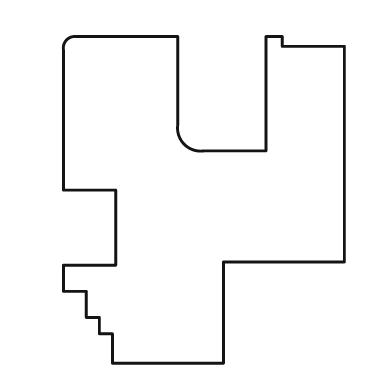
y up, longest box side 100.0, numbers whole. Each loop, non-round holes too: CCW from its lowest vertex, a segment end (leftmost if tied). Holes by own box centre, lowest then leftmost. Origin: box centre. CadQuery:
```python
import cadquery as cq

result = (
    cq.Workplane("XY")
    .moveTo(-28.0, -50.0)
    .lineTo(6.0, -50.0)
    .lineTo(6.0, -19.0)
    .lineTo(43.0, -19.0)
    .lineTo(43.0, 47.0)
    .lineTo(24.0, 47.0)
    .lineTo(24.0, 50.0)
    .lineTo(19.0, 50.0)
    .lineTo(19.0, 15.0)
    .lineTo(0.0, 15.0)
    .threePointArc((-6.0, 17.0), (-8.0, 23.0))
    .lineTo(-8.0, 50.0)
    .lineTo(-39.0, 50.0)
    .threePointArc((-42.0, 49.0), (-43.0, 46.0))
    .lineTo(-43.0, 3.0)
    .lineTo(-27.0, 3.0)
    .lineTo(-27.0, -20.0)
    .lineTo(-43.0, -20.0)
    .lineTo(-43.0, -28.0)
    .lineTo(-36.0, -28.0)
    .lineTo(-36.0, -36.0)
    .lineTo(-32.0, -36.0)
    .lineTo(-32.0, -41.0)
    .lineTo(-28.0, -41.0)
    .close()
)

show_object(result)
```